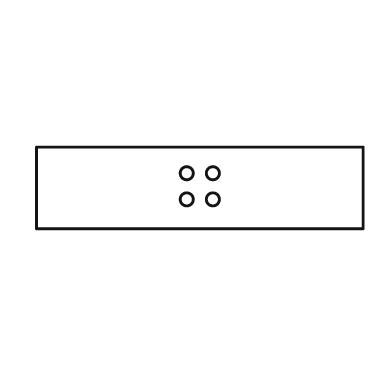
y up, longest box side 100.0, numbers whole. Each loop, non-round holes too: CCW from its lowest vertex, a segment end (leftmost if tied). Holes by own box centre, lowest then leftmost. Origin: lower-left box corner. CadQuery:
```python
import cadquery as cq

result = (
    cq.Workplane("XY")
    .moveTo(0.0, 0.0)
    .lineTo(100.0, 0.0)
    .lineTo(100.0, 25.0)
    .lineTo(0.0, 25.0)
    .close()
    .moveTo(46.0, 9.0)
    .circle(2.0)
    .moveTo(54.0, 9.0)
    .circle(2.0)
    .moveTo(46.0, 17.0)
    .circle(2.0)
    .moveTo(54.0, 17.0)
    .circle(2.0)
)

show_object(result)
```